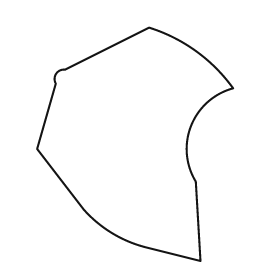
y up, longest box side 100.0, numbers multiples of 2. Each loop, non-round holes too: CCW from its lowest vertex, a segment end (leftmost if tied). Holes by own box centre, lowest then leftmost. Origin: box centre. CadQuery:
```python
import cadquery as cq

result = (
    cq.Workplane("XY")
    .moveTo(28.0, -50.0)
    .lineTo(26.0, -16.0)
    .threePointArc((24.0, 8.0), (42.0, 24.0))
    .threePointArc((26.0, 40.0), (6.0, 50.0))
    .lineTo(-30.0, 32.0)
    .threePointArc((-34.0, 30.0), (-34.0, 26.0))
    .lineTo(-42.0, -2.0)
    .lineTo(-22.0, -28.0)
    .threePointArc((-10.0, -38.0), (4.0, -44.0))
    .close()
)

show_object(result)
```